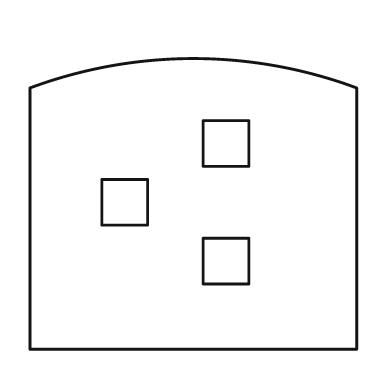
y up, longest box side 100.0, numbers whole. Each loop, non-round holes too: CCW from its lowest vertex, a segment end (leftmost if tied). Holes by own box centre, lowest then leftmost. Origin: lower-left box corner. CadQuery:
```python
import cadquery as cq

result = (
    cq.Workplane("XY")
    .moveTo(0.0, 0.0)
    .lineTo(100.0, 0.0)
    .lineTo(100.0, 80.0)
    .threePointArc((50.0, 89.0), (0.0, 80.0))
    .close()
    .moveTo(53.0, 20.0)
    .lineTo(67.0, 20.0)
    .lineTo(67.0, 34.0)
    .lineTo(53.0, 34.0)
    .close()
    .moveTo(22.0, 38.0)
    .lineTo(36.0, 38.0)
    .lineTo(36.0, 52.0)
    .lineTo(22.0, 52.0)
    .close()
    .moveTo(53.0, 56.0)
    .lineTo(67.0, 56.0)
    .lineTo(67.0, 70.0)
    .lineTo(53.0, 70.0)
    .close()
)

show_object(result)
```